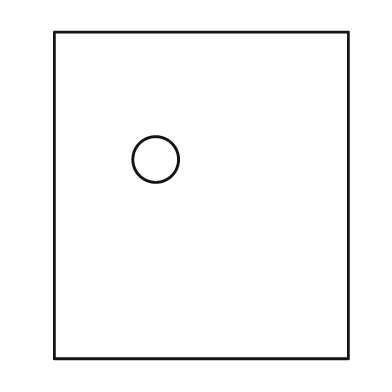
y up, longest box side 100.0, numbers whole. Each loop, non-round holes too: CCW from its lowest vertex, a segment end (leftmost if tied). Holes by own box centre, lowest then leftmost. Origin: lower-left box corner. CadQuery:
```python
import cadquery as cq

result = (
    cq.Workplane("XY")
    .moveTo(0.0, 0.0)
    .lineTo(90.0, 0.0)
    .lineTo(90.0, 100.0)
    .lineTo(0.0, 100.0)
    .close()
    .moveTo(31.0, 61.0)
    .circle(7.0)
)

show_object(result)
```